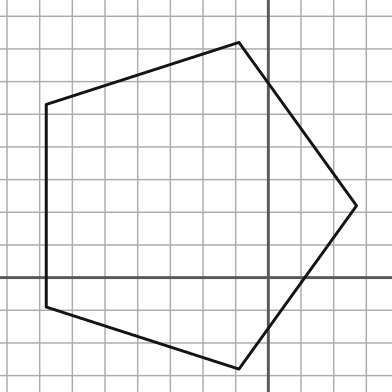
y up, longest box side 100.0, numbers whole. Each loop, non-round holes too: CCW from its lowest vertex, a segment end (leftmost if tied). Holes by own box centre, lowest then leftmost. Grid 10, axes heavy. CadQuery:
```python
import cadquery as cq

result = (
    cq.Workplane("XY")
    .moveTo(-9.0, -28.0)
    .lineTo(27.0, 22.0)
    .lineTo(-9.0, 72.0)
    .lineTo(-68.0, 53.0)
    .lineTo(-68.0, -9.0)
    .close()
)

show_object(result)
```